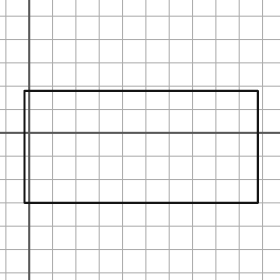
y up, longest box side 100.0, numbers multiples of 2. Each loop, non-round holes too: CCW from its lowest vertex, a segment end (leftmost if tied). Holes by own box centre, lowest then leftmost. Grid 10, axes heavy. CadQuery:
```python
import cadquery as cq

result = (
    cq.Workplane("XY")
    .moveTo(-2.0, -30.0)
    .lineTo(98.0, -30.0)
    .lineTo(98.0, 18.0)
    .lineTo(-2.0, 18.0)
    .close()
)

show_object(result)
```